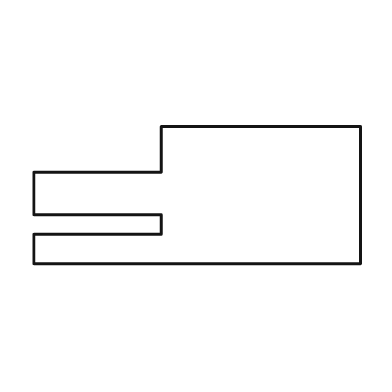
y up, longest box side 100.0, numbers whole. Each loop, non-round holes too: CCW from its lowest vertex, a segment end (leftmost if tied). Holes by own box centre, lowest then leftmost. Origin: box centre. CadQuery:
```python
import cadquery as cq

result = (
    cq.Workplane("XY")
    .moveTo(-50.0, -21.0)
    .lineTo(50.0, -21.0)
    .lineTo(50.0, 21.0)
    .lineTo(-11.0, 21.0)
    .lineTo(-11.0, 7.0)
    .lineTo(-50.0, 7.0)
    .lineTo(-50.0, -6.0)
    .lineTo(-11.0, -6.0)
    .lineTo(-11.0, -12.0)
    .lineTo(-50.0, -12.0)
    .close()
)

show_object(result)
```